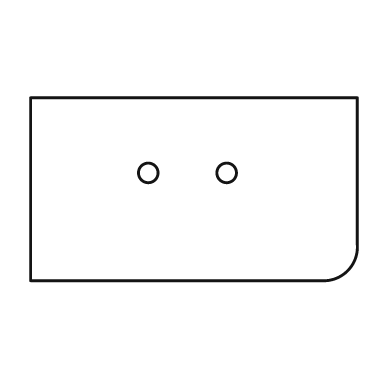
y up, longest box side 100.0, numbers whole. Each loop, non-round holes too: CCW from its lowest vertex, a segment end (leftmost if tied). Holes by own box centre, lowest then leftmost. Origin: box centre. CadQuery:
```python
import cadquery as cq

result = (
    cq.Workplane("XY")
    .moveTo(-50.0, -28.0)
    .lineTo(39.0, -28.0)
    .threePointArc((47.0, -25.0), (50.0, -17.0))
    .lineTo(50.0, 28.0)
    .lineTo(-50.0, 28.0)
    .close()
    .moveTo(-14.0, 5.0)
    .circle(3.0)
    .moveTo(10.0, 5.0)
    .circle(3.0)
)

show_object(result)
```